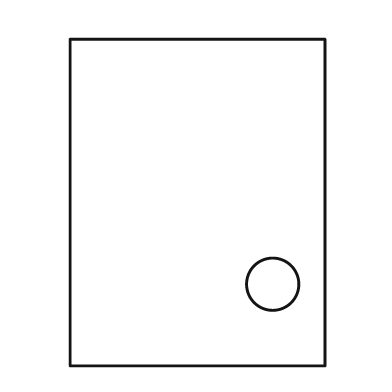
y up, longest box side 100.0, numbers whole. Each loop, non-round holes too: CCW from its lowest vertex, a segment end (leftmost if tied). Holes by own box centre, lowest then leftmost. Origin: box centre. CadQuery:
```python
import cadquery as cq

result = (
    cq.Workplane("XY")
    .moveTo(-39.0, -50.0)
    .lineTo(39.0, -50.0)
    .lineTo(39.0, 50.0)
    .lineTo(-39.0, 50.0)
    .close()
    .moveTo(23.0, -25.0)
    .circle(8.0)
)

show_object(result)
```